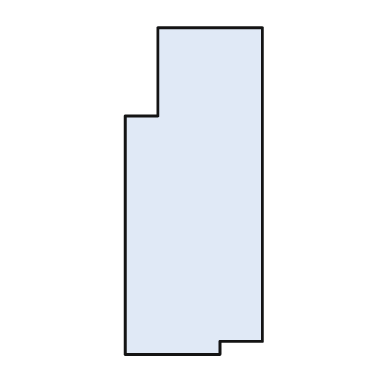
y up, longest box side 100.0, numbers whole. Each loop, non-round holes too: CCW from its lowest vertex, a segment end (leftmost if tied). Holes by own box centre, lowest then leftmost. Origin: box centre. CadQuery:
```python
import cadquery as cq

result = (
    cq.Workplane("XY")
    .moveTo(-21.0, -50.0)
    .lineTo(8.0, -50.0)
    .lineTo(8.0, -46.0)
    .lineTo(21.0, -46.0)
    .lineTo(21.0, 50.0)
    .lineTo(-11.0, 50.0)
    .lineTo(-11.0, 23.0)
    .lineTo(-21.0, 23.0)
    .close()
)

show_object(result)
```